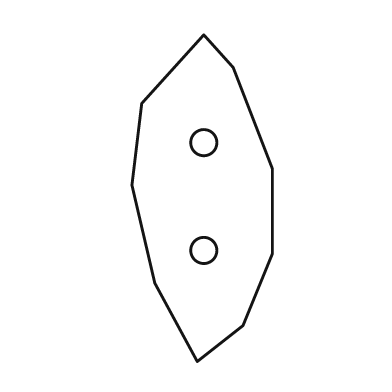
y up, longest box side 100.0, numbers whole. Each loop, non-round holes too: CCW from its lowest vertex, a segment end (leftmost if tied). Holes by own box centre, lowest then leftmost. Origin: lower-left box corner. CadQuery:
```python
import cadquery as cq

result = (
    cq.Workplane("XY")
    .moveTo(20.0, 0.0)
    .lineTo(34.0, 11.0)
    .lineTo(43.0, 33.0)
    .lineTo(43.0, 59.0)
    .lineTo(31.0, 90.0)
    .lineTo(22.0, 100.0)
    .lineTo(3.0, 79.0)
    .lineTo(0.0, 54.0)
    .lineTo(7.0, 24.0)
    .close()
    .moveTo(22.0, 34.0)
    .circle(4.0)
    .moveTo(22.0, 67.0)
    .circle(4.0)
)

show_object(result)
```